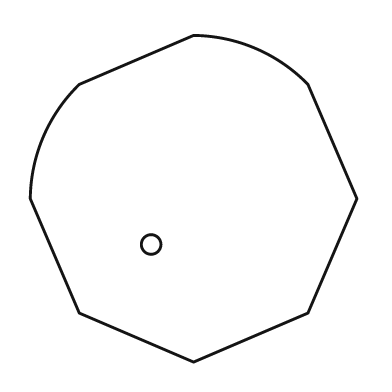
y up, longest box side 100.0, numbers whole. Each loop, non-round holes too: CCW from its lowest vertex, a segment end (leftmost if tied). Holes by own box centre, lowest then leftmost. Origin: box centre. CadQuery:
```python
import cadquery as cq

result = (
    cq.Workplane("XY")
    .moveTo(0.0, -50.0)
    .lineTo(35.0, -35.0)
    .lineTo(50.0, 0.0)
    .lineTo(35.0, 35.0)
    .threePointArc((19.0, 46.0), (0.0, 50.0))
    .lineTo(-35.0, 35.0)
    .threePointArc((-46.0, 19.0), (-50.0, 0.0))
    .lineTo(-35.0, -35.0)
    .close()
    .moveTo(-13.0, -14.0)
    .circle(3.0)
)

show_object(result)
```